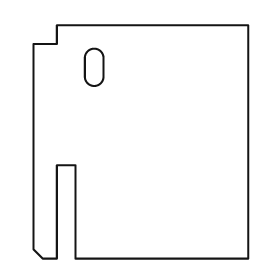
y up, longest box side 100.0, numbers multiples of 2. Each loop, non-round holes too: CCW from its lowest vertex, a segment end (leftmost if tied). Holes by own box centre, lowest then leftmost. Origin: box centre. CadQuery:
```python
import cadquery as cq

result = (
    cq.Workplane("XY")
    .moveTo(-42.0, -50.0)
    .lineTo(-36.0, -50.0)
    .lineTo(-36.0, -10.0)
    .lineTo(-28.0, -10.0)
    .lineTo(-28.0, -50.0)
    .lineTo(46.0, -50.0)
    .lineTo(46.0, 50.0)
    .lineTo(-36.0, 50.0)
    .lineTo(-36.0, 42.0)
    .lineTo(-46.0, 42.0)
    .lineTo(-46.0, -46.0)
    .close()
    .moveTo(-24.0, 28.0)
    .threePointArc((-20.0, 24.0), (-16.0, 28.0))
    .lineTo(-16.0, 36.0)
    .threePointArc((-20.0, 40.0), (-24.0, 36.0))
    .close()
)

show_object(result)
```